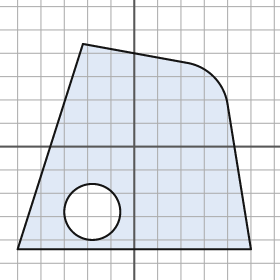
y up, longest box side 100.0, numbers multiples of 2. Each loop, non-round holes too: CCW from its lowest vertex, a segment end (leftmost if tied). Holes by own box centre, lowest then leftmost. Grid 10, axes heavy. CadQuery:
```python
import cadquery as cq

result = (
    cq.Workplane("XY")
    .moveTo(-50.0, -44.0)
    .lineTo(50.0, -44.0)
    .lineTo(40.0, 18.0)
    .threePointArc((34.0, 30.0), (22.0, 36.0))
    .lineTo(-22.0, 44.0)
    .close()
    .moveTo(-18.0, -28.0)
    .circle(12.0)
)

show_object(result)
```